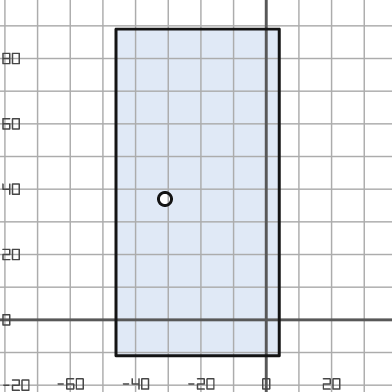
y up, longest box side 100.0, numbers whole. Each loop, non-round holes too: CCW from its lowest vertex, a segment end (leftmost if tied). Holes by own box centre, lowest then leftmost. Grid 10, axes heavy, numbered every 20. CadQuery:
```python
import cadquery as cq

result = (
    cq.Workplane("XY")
    .moveTo(-46.0, -11.0)
    .lineTo(4.0, -11.0)
    .lineTo(4.0, 89.0)
    .lineTo(-46.0, 89.0)
    .close()
    .moveTo(-31.0, 37.0)
    .circle(2.0)
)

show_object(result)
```